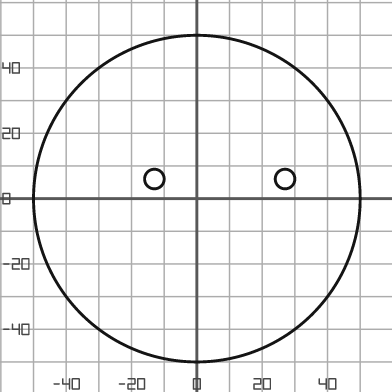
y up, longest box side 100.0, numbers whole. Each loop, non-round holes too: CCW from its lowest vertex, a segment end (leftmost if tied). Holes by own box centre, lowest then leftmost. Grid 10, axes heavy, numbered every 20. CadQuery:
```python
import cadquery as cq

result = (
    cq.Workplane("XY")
    .moveTo(0.0, 0.0)
    .circle(50.0)
    .moveTo(-13.0, 6.0)
    .circle(3.0)
    .moveTo(27.0, 6.0)
    .circle(3.0)
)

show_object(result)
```